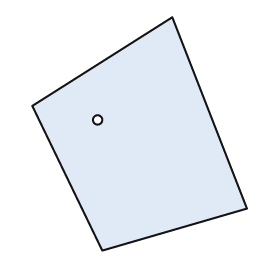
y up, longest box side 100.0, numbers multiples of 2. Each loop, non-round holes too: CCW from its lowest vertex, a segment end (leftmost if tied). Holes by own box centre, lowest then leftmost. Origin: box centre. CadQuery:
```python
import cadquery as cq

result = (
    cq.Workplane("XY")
    .moveTo(-16.0, -50.0)
    .lineTo(46.0, -32.0)
    .lineTo(14.0, 50.0)
    .lineTo(-46.0, 12.0)
    .close()
    .moveTo(-18.0, 6.0)
    .circle(2.0)
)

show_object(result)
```